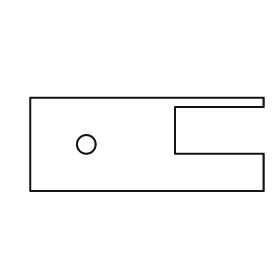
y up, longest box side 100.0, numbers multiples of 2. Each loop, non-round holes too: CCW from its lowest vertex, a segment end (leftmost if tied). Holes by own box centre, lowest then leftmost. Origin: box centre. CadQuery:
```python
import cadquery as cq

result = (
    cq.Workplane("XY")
    .moveTo(-50.0, -20.0)
    .lineTo(50.0, -20.0)
    .lineTo(50.0, -4.0)
    .lineTo(12.0, -4.0)
    .lineTo(12.0, 16.0)
    .lineTo(50.0, 16.0)
    .lineTo(50.0, 20.0)
    .lineTo(-50.0, 20.0)
    .close()
    .moveTo(-26.0, 0.0)
    .circle(4.0)
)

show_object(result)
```